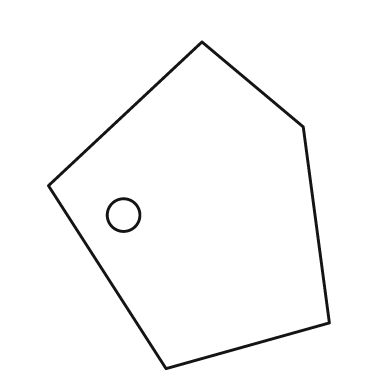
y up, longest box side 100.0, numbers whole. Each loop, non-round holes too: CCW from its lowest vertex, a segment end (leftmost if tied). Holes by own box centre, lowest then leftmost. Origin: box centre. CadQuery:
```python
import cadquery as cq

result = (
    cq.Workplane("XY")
    .moveTo(-7.0, -50.0)
    .lineTo(43.0, -36.0)
    .lineTo(35.0, 24.0)
    .lineTo(4.0, 50.0)
    .lineTo(-43.0, 6.0)
    .close()
    .moveTo(-20.0, -3.0)
    .circle(5.0)
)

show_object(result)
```